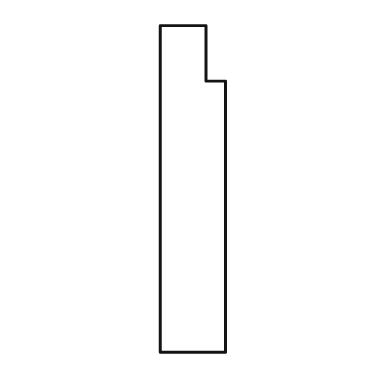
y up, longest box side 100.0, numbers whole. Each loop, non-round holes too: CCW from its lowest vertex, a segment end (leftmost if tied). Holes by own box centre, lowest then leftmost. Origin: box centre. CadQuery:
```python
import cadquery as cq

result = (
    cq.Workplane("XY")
    .moveTo(-10.0, -50.0)
    .lineTo(10.0, -50.0)
    .lineTo(10.0, 33.0)
    .lineTo(4.0, 33.0)
    .lineTo(4.0, 50.0)
    .lineTo(-10.0, 50.0)
    .close()
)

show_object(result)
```